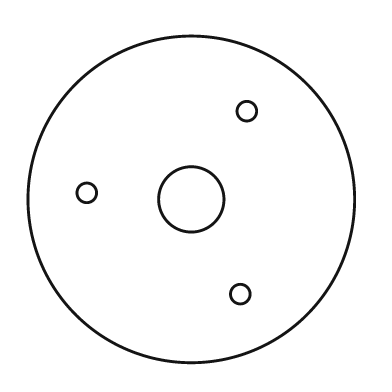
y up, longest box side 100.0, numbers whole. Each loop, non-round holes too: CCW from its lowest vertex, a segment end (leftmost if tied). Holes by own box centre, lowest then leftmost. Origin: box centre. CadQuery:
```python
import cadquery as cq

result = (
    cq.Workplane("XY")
    .moveTo(0.0, 0.0)
    .circle(50.0)
    .moveTo(15.0, -29.0)
    .circle(3.0)
    .moveTo(0.0, 0.0)
    .circle(10.0)
    .moveTo(-32.0, 2.0)
    .circle(3.0)
    .moveTo(17.0, 27.0)
    .circle(3.0)
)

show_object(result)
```